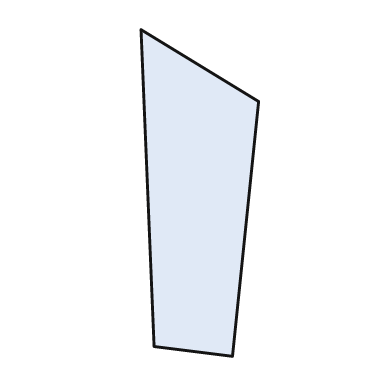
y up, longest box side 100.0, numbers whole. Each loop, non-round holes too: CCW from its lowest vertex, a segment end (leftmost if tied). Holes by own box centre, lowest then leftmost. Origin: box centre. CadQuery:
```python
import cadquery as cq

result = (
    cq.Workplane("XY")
    .moveTo(10.0, -50.0)
    .lineTo(18.0, 28.0)
    .lineTo(-18.0, 50.0)
    .lineTo(-14.0, -47.0)
    .close()
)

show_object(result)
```